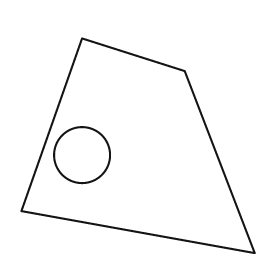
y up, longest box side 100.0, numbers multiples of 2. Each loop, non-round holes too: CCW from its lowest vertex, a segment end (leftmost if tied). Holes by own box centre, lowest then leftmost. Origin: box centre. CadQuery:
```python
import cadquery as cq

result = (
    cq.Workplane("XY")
    .moveTo(50.0, -46.0)
    .lineTo(20.0, 32.0)
    .lineTo(-24.0, 46.0)
    .lineTo(-50.0, -28.0)
    .close()
    .moveTo(-24.0, -4.0)
    .circle(12.0)
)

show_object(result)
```